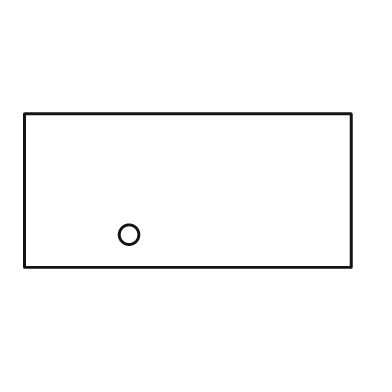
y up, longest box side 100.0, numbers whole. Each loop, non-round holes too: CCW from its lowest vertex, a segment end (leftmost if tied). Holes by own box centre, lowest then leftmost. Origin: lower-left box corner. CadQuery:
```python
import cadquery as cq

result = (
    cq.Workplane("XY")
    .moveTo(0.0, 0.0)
    .lineTo(100.0, 0.0)
    .lineTo(100.0, 47.0)
    .lineTo(0.0, 47.0)
    .close()
    .moveTo(32.0, 10.0)
    .circle(3.0)
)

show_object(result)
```